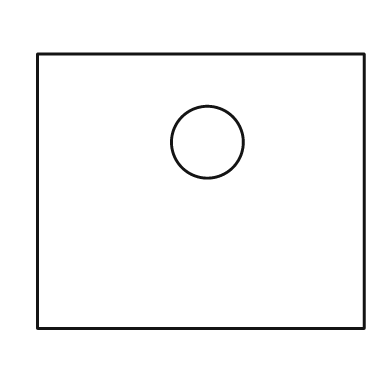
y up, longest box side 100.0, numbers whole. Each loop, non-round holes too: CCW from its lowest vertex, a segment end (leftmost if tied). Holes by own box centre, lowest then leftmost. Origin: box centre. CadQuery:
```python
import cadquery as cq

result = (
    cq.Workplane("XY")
    .moveTo(-50.0, -42.0)
    .lineTo(50.0, -42.0)
    .lineTo(50.0, 42.0)
    .lineTo(-50.0, 42.0)
    .close()
    .moveTo(2.0, 15.0)
    .circle(11.0)
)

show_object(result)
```